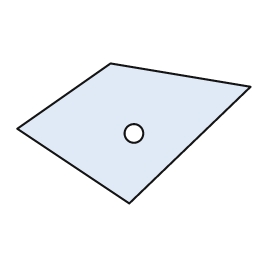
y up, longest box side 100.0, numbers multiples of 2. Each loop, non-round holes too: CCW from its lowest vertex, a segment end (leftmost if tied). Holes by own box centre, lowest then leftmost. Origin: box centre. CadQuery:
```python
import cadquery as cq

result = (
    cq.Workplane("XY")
    .moveTo(-2.0, -30.0)
    .lineTo(50.0, 20.0)
    .lineTo(-10.0, 30.0)
    .lineTo(-50.0, 2.0)
    .close()
    .moveTo(0.0, 0.0)
    .circle(4.0)
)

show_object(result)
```